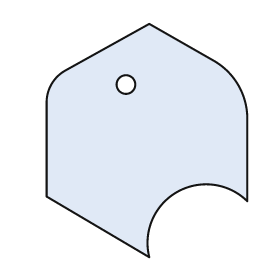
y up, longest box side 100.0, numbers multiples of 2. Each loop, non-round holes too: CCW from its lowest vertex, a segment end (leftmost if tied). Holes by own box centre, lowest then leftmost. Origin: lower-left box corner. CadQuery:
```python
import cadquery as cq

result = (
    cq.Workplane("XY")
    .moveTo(44.0, 0.0)
    .threePointArc((56.0, 28.0), (86.0, 24.0))
    .lineTo(86.0, 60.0)
    .threePointArc((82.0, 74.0), (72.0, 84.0))
    .lineTo(44.0, 100.0)
    .lineTo(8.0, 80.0)
    .threePointArc((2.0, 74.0), (0.0, 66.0))
    .lineTo(0.0, 26.0)
    .close()
    .moveTo(34.0, 74.0)
    .circle(4.0)
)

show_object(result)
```